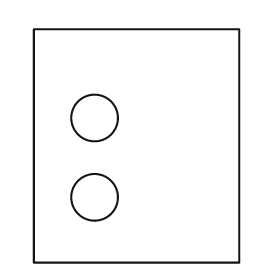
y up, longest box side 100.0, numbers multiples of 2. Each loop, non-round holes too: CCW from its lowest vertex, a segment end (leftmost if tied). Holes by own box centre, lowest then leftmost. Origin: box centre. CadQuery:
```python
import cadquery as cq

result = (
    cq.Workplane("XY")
    .moveTo(-44.0, -50.0)
    .lineTo(44.0, -50.0)
    .lineTo(44.0, 50.0)
    .lineTo(-44.0, 50.0)
    .close()
    .moveTo(-18.0, -22.0)
    .circle(10.0)
    .moveTo(-18.0, 12.0)
    .circle(10.0)
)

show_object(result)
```